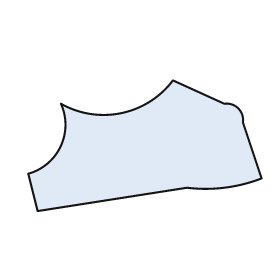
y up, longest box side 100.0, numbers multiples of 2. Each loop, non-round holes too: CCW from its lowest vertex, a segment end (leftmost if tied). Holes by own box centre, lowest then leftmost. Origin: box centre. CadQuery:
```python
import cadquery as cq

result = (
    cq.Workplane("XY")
    .moveTo(-46.0, -28.0)
    .lineTo(18.0, -18.0)
    .threePointArc((34.0, -18.0), (50.0, -14.0))
    .lineTo(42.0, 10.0)
    .threePointArc((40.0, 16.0), (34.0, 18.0))
    .lineTo(12.0, 28.0)
    .threePointArc((-10.0, 14.0), (-36.0, 18.0))
    .threePointArc((-36.0, 0.0), (-50.0, -12.0))
    .close()
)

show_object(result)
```